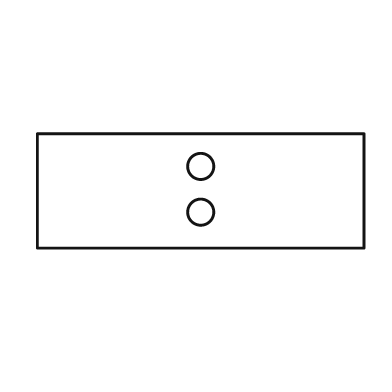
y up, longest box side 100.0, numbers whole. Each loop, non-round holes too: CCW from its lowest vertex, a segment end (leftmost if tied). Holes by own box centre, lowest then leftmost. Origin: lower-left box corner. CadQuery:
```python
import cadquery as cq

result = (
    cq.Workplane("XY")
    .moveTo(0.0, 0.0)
    .lineTo(100.0, 0.0)
    .lineTo(100.0, 35.0)
    .lineTo(0.0, 35.0)
    .close()
    .moveTo(50.0, 11.0)
    .circle(4.0)
    .moveTo(50.0, 25.0)
    .circle(4.0)
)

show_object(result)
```